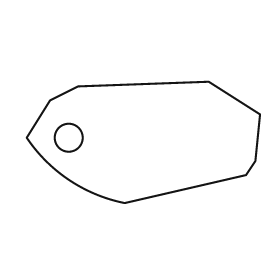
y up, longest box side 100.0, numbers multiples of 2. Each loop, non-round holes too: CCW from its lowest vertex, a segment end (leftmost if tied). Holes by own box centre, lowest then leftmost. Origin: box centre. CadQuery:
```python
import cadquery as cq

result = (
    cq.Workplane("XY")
    .moveTo(-8.0, -26.0)
    .lineTo(44.0, -14.0)
    .lineTo(48.0, -8.0)
    .lineTo(50.0, 12.0)
    .lineTo(28.0, 26.0)
    .lineTo(-28.0, 24.0)
    .lineTo(-40.0, 18.0)
    .lineTo(-50.0, 2.0)
    .threePointArc((-32.0, -16.0), (-8.0, -26.0))
    .close()
    .moveTo(-32.0, 2.0)
    .circle(6.0)
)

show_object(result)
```